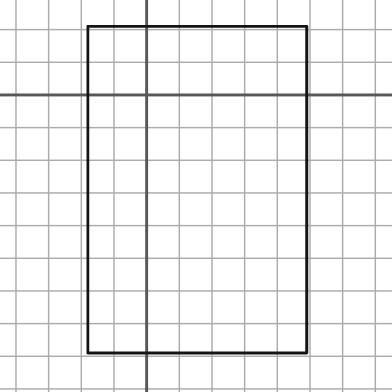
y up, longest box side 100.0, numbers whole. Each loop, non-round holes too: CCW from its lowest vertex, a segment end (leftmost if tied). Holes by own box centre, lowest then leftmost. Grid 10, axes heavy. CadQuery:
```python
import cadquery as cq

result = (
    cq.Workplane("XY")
    .moveTo(-18.0, -79.0)
    .lineTo(49.0, -79.0)
    .lineTo(49.0, 21.0)
    .lineTo(-18.0, 21.0)
    .close()
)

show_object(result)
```